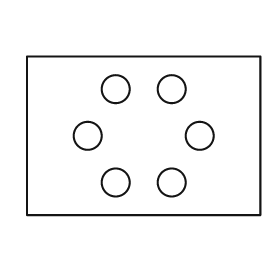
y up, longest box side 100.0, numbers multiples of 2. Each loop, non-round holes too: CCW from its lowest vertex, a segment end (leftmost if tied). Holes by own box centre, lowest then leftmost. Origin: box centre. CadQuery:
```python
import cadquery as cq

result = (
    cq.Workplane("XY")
    .moveTo(-50.0, -34.0)
    .lineTo(50.0, -34.0)
    .lineTo(50.0, 34.0)
    .lineTo(-50.0, 34.0)
    .close()
    .moveTo(-12.0, -20.0)
    .circle(6.0)
    .moveTo(12.0, -20.0)
    .circle(6.0)
    .moveTo(-24.0, 0.0)
    .circle(6.0)
    .moveTo(24.0, 0.0)
    .circle(6.0)
    .moveTo(-12.0, 20.0)
    .circle(6.0)
    .moveTo(12.0, 20.0)
    .circle(6.0)
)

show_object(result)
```